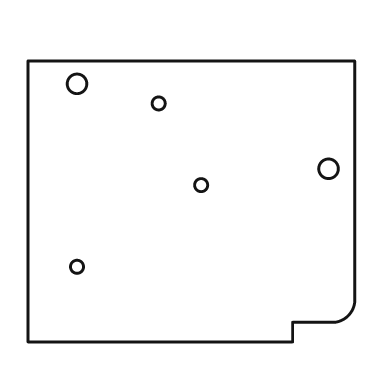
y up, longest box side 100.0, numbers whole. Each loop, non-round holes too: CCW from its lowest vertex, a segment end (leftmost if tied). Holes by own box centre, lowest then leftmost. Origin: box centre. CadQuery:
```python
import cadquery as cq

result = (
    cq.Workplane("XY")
    .moveTo(-50.0, -43.0)
    .lineTo(31.0, -43.0)
    .lineTo(31.0, -37.0)
    .lineTo(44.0, -37.0)
    .threePointArc((48.0, -35.0), (50.0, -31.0))
    .lineTo(50.0, 43.0)
    .lineTo(-50.0, 43.0)
    .close()
    .moveTo(-35.0, -20.0)
    .circle(2.0)
    .moveTo(3.0, 5.0)
    .circle(2.0)
    .moveTo(42.0, 10.0)
    .circle(3.0)
    .moveTo(-10.0, 30.0)
    .circle(2.0)
    .moveTo(-35.0, 36.0)
    .circle(3.0)
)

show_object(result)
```